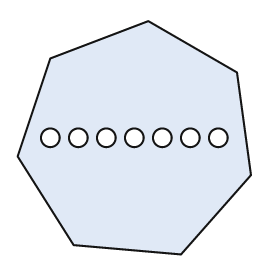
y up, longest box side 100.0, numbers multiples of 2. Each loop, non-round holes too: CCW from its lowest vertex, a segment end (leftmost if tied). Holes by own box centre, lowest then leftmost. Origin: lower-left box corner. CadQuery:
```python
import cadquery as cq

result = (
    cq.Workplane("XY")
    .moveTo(70.0, 0.0)
    .lineTo(100.0, 34.0)
    .lineTo(94.0, 78.0)
    .lineTo(56.0, 100.0)
    .lineTo(14.0, 84.0)
    .lineTo(0.0, 42.0)
    .lineTo(24.0, 4.0)
    .close()
    .moveTo(14.0, 50.0)
    .circle(4.0)
    .moveTo(26.0, 50.0)
    .circle(4.0)
    .moveTo(38.0, 50.0)
    .circle(4.0)
    .moveTo(50.0, 50.0)
    .circle(4.0)
    .moveTo(62.0, 50.0)
    .circle(4.0)
    .moveTo(74.0, 50.0)
    .circle(4.0)
    .moveTo(86.0, 50.0)
    .circle(4.0)
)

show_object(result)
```